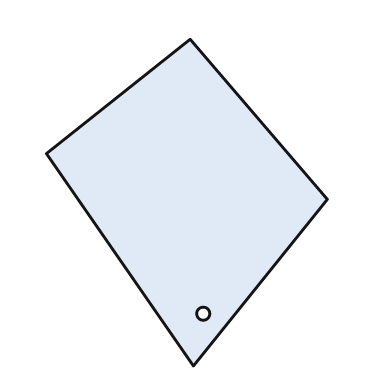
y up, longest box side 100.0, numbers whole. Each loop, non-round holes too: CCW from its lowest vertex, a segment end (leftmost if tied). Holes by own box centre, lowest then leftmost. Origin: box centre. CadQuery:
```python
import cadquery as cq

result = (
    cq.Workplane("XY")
    .moveTo(2.0, -50.0)
    .lineTo(43.0, 1.0)
    .lineTo(1.0, 50.0)
    .lineTo(-43.0, 15.0)
    .close()
    .moveTo(5.0, -34.0)
    .circle(2.0)
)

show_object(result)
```